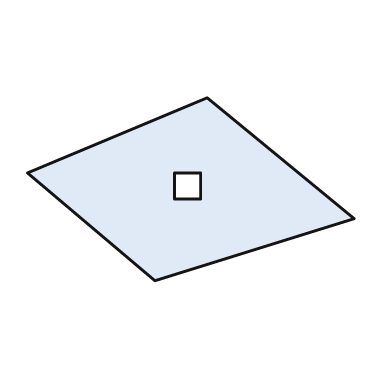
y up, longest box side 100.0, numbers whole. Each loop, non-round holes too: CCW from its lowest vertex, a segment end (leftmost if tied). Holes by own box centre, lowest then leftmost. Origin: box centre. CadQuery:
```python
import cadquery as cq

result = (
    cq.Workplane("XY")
    .moveTo(-11.0, -28.0)
    .lineTo(50.0, -9.0)
    .lineTo(5.0, 28.0)
    .lineTo(-50.0, 5.0)
    .close()
    .moveTo(-5.0, -3.0)
    .lineTo(3.0, -3.0)
    .lineTo(3.0, 5.0)
    .lineTo(-5.0, 5.0)
    .close()
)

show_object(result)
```